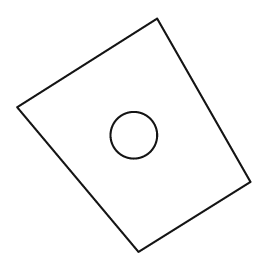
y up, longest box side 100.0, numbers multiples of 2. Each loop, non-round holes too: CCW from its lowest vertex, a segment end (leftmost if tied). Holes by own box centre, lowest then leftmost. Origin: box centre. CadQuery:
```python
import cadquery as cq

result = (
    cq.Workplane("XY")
    .moveTo(2.0, -50.0)
    .lineTo(50.0, -20.0)
    .lineTo(10.0, 50.0)
    .lineTo(-50.0, 12.0)
    .close()
    .moveTo(0.0, 0.0)
    .circle(10.0)
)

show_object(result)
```